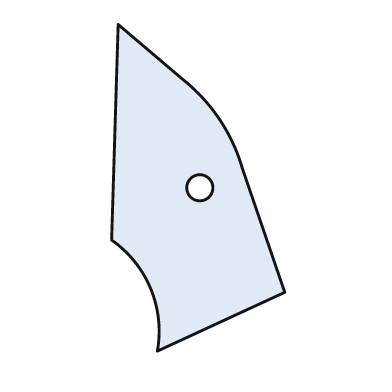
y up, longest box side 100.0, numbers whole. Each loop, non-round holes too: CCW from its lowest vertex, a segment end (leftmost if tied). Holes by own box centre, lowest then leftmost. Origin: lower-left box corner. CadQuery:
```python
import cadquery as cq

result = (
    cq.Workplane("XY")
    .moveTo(14.0, 0.0)
    .lineTo(53.0, 18.0)
    .lineTo(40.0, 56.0)
    .threePointArc((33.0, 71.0), (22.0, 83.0))
    .lineTo(2.0, 100.0)
    .lineTo(0.0, 34.0)
    .threePointArc((12.0, 19.0), (14.0, 0.0))
    .close()
    .moveTo(27.0, 50.0)
    .circle(4.0)
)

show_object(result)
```